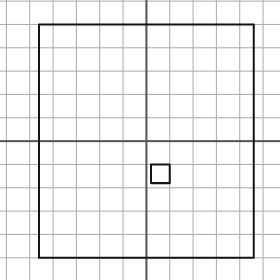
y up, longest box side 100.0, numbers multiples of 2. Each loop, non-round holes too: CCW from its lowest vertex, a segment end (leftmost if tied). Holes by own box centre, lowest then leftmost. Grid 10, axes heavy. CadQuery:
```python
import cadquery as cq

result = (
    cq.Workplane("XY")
    .moveTo(-46.0, -50.0)
    .lineTo(46.0, -50.0)
    .lineTo(46.0, 50.0)
    .lineTo(-46.0, 50.0)
    .close()
    .moveTo(2.0, -18.0)
    .lineTo(10.0, -18.0)
    .lineTo(10.0, -10.0)
    .lineTo(2.0, -10.0)
    .close()
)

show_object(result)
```